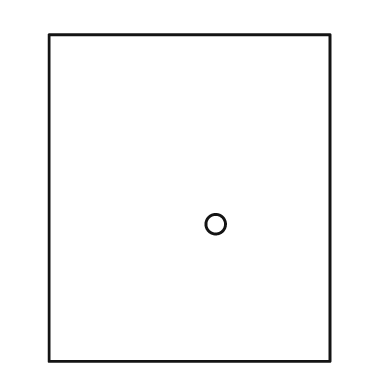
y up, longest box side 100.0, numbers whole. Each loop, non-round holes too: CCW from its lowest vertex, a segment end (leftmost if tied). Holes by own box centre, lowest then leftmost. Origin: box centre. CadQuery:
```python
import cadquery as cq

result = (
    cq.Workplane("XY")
    .moveTo(-43.0, -50.0)
    .lineTo(43.0, -50.0)
    .lineTo(43.0, 50.0)
    .lineTo(-43.0, 50.0)
    .close()
    .moveTo(8.0, -8.0)
    .circle(3.0)
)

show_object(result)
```